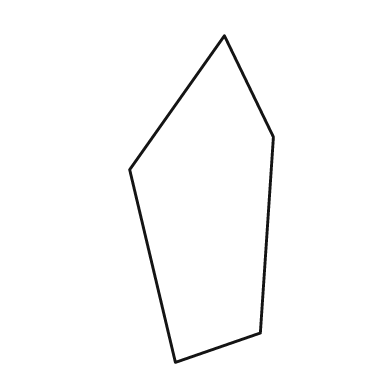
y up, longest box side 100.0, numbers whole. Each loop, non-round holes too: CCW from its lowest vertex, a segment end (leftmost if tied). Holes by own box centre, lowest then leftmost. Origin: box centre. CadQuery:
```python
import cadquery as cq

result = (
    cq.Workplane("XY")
    .moveTo(-8.0, -50.0)
    .lineTo(18.0, -41.0)
    .lineTo(22.0, 19.0)
    .lineTo(7.0, 50.0)
    .lineTo(-22.0, 9.0)
    .close()
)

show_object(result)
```